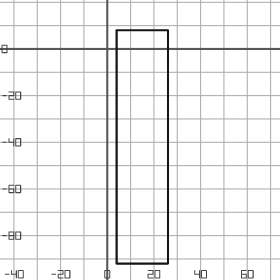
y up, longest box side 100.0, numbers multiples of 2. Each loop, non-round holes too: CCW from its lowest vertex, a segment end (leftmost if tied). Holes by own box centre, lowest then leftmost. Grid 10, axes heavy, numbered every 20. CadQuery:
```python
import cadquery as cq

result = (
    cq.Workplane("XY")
    .moveTo(4.0, -92.0)
    .lineTo(26.0, -92.0)
    .lineTo(26.0, 8.0)
    .lineTo(4.0, 8.0)
    .close()
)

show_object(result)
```